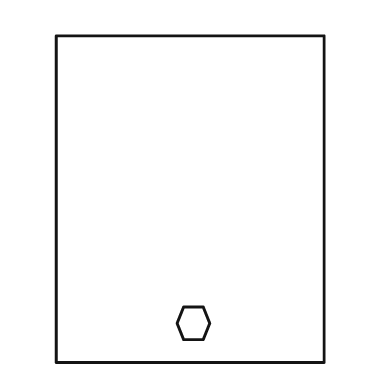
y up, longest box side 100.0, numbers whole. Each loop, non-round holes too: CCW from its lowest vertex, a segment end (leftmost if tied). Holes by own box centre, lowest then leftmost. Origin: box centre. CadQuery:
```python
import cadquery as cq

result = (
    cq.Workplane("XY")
    .moveTo(-41.0, -50.0)
    .lineTo(41.0, -50.0)
    .lineTo(41.0, 50.0)
    .lineTo(-41.0, 50.0)
    .close()
    .moveTo(-2.0, -43.0)
    .lineTo(4.0, -43.0)
    .lineTo(6.0, -38.0)
    .lineTo(4.0, -33.0)
    .lineTo(-2.0, -33.0)
    .lineTo(-4.0, -38.0)
    .close()
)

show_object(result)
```